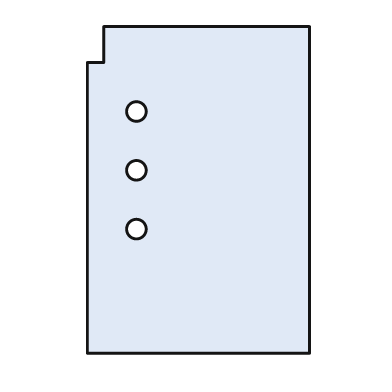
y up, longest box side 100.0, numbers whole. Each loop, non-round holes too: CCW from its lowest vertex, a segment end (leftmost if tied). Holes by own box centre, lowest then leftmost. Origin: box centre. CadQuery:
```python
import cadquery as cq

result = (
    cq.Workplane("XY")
    .moveTo(-34.0, -50.0)
    .lineTo(34.0, -50.0)
    .lineTo(34.0, 50.0)
    .lineTo(-29.0, 50.0)
    .lineTo(-29.0, 39.0)
    .lineTo(-34.0, 39.0)
    .close()
    .moveTo(-19.0, -12.0)
    .circle(3.0)
    .moveTo(-19.0, 6.0)
    .circle(3.0)
    .moveTo(-19.0, 24.0)
    .circle(3.0)
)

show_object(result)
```